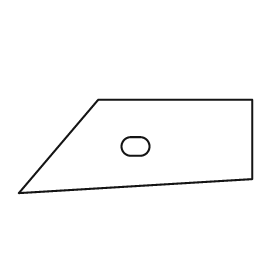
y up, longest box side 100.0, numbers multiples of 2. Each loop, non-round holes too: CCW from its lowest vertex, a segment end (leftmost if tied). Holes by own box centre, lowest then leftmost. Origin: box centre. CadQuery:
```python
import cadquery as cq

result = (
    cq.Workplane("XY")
    .moveTo(-50.0, -20.0)
    .lineTo(50.0, -14.0)
    .lineTo(50.0, 20.0)
    .lineTo(-16.0, 20.0)
    .close()
    .moveTo(-2.0, -4.0)
    .lineTo(2.0, -4.0)
    .threePointArc((6.0, 0.0), (2.0, 4.0))
    .lineTo(-2.0, 4.0)
    .threePointArc((-6.0, 0.0), (-2.0, -4.0))
    .close()
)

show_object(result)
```